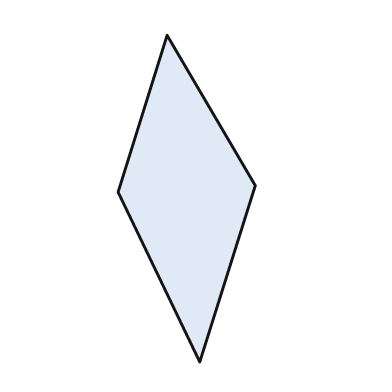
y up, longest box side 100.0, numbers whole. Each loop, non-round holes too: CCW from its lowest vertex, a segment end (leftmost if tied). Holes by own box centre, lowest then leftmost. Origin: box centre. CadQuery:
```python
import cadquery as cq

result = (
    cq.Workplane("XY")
    .moveTo(4.0, -50.0)
    .lineTo(21.0, 4.0)
    .lineTo(-6.0, 50.0)
    .lineTo(-21.0, 2.0)
    .close()
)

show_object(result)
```